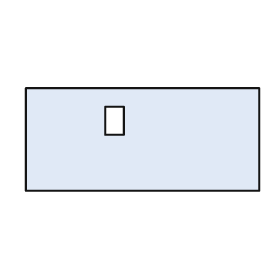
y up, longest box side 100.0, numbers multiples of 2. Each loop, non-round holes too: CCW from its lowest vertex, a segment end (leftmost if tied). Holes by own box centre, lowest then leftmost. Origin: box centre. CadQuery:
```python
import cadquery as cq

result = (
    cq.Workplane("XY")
    .moveTo(-50.0, -22.0)
    .lineTo(50.0, -22.0)
    .lineTo(50.0, 22.0)
    .lineTo(-50.0, 22.0)
    .close()
    .moveTo(-16.0, 2.0)
    .lineTo(-8.0, 2.0)
    .lineTo(-8.0, 14.0)
    .lineTo(-16.0, 14.0)
    .close()
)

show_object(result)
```